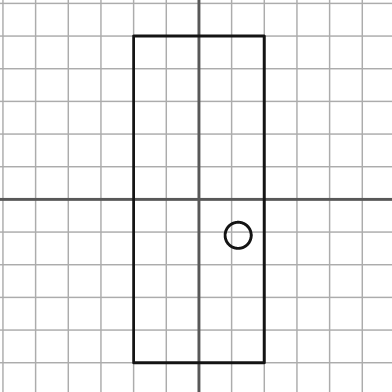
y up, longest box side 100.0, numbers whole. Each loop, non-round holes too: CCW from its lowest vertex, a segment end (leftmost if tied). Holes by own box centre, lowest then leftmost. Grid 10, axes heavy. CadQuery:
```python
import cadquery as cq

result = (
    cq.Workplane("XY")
    .moveTo(-20.0, -50.0)
    .lineTo(20.0, -50.0)
    .lineTo(20.0, 50.0)
    .lineTo(-20.0, 50.0)
    .close()
    .moveTo(12.0, -11.0)
    .circle(4.0)
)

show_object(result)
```